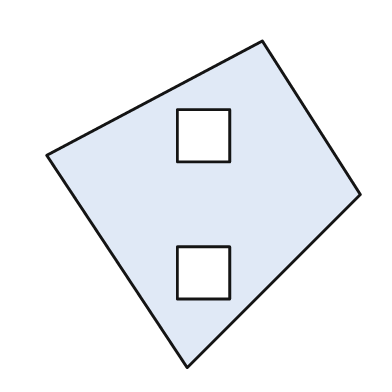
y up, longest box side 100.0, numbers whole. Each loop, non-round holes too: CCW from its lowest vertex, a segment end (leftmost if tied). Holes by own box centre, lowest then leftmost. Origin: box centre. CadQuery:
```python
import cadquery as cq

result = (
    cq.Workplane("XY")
    .moveTo(-5.0, -50.0)
    .lineTo(48.0, 3.0)
    .lineTo(18.0, 50.0)
    .lineTo(-48.0, 15.0)
    .close()
    .moveTo(-8.0, -29.0)
    .lineTo(8.0, -29.0)
    .lineTo(8.0, -13.0)
    .lineTo(-8.0, -13.0)
    .close()
    .moveTo(-8.0, 13.0)
    .lineTo(8.0, 13.0)
    .lineTo(8.0, 29.0)
    .lineTo(-8.0, 29.0)
    .close()
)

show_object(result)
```